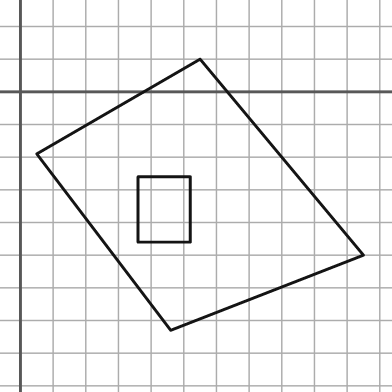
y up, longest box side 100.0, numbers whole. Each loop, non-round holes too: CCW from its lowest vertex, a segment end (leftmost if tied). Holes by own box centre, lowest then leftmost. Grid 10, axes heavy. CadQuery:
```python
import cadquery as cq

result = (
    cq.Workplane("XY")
    .moveTo(46.0, -73.0)
    .lineTo(105.0, -50.0)
    .lineTo(55.0, 10.0)
    .lineTo(5.0, -19.0)
    .close()
    .moveTo(36.0, -46.0)
    .lineTo(52.0, -46.0)
    .lineTo(52.0, -26.0)
    .lineTo(36.0, -26.0)
    .close()
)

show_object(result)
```